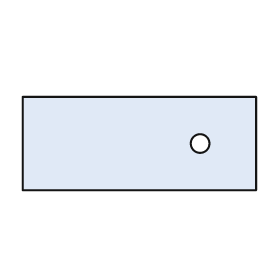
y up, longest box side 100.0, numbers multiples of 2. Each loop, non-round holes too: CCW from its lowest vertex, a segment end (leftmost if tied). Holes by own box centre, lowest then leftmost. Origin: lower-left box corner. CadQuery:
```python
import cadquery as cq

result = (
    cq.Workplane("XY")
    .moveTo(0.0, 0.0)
    .lineTo(100.0, 0.0)
    .lineTo(100.0, 40.0)
    .lineTo(0.0, 40.0)
    .close()
    .moveTo(76.0, 20.0)
    .circle(4.0)
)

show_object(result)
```